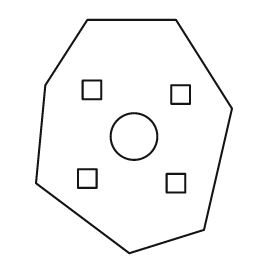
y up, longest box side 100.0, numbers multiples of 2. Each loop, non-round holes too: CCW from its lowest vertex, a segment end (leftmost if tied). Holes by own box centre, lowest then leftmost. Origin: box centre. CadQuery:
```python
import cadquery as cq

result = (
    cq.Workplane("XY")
    .moveTo(-2.0, -50.0)
    .lineTo(30.0, -40.0)
    .lineTo(42.0, 12.0)
    .lineTo(18.0, 50.0)
    .lineTo(-20.0, 50.0)
    .lineTo(-38.0, 22.0)
    .lineTo(-42.0, -20.0)
    .close()
    .moveTo(14.0, -24.0)
    .lineTo(22.0, -24.0)
    .lineTo(22.0, -16.0)
    .lineTo(14.0, -16.0)
    .close()
    .moveTo(-24.0, -22.0)
    .lineTo(-16.0, -22.0)
    .lineTo(-16.0, -14.0)
    .lineTo(-24.0, -14.0)
    .close()
    .moveTo(0.0, 0.0)
    .circle(10.0)
    .moveTo(16.0, 14.0)
    .lineTo(24.0, 14.0)
    .lineTo(24.0, 22.0)
    .lineTo(16.0, 22.0)
    .close()
    .moveTo(-22.0, 16.0)
    .lineTo(-14.0, 16.0)
    .lineTo(-14.0, 24.0)
    .lineTo(-22.0, 24.0)
    .close()
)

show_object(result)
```